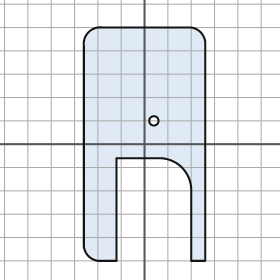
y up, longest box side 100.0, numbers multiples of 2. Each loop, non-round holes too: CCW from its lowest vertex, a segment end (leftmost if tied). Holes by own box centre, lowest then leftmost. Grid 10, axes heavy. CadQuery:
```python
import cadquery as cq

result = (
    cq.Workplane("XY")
    .moveTo(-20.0, -50.0)
    .lineTo(-12.0, -50.0)
    .lineTo(-12.0, -6.0)
    .lineTo(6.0, -6.0)
    .threePointArc((16.0, -10.0), (20.0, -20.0))
    .lineTo(20.0, -50.0)
    .lineTo(26.0, -50.0)
    .lineTo(26.0, 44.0)
    .threePointArc((24.0, 48.0), (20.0, 50.0))
    .lineTo(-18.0, 50.0)
    .threePointArc((-24.0, 48.0), (-26.0, 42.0))
    .lineTo(-26.0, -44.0)
    .threePointArc((-24.0, -48.0), (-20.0, -50.0))
    .close()
    .moveTo(4.0, 10.0)
    .circle(2.0)
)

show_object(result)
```